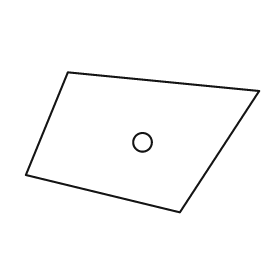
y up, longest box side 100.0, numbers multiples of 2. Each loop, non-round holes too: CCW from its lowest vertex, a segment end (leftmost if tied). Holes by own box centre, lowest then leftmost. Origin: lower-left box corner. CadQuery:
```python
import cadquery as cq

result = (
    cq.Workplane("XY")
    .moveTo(66.0, 0.0)
    .lineTo(100.0, 52.0)
    .lineTo(18.0, 60.0)
    .lineTo(0.0, 16.0)
    .close()
    .moveTo(50.0, 30.0)
    .circle(4.0)
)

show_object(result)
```